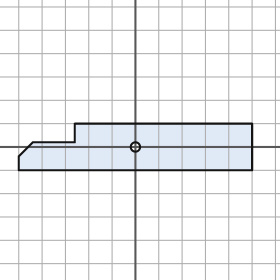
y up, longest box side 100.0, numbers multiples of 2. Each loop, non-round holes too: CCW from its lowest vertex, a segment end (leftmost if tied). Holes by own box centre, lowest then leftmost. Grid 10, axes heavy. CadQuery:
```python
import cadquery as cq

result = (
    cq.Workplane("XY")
    .moveTo(-50.0, -10.0)
    .lineTo(50.0, -10.0)
    .lineTo(50.0, 10.0)
    .lineTo(-26.0, 10.0)
    .lineTo(-26.0, 2.0)
    .lineTo(-44.0, 2.0)
    .lineTo(-50.0, -4.0)
    .close()
    .moveTo(0.0, 0.0)
    .circle(2.0)
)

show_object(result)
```